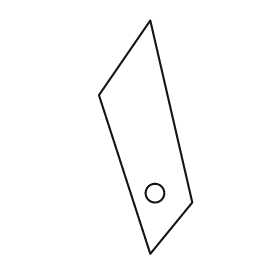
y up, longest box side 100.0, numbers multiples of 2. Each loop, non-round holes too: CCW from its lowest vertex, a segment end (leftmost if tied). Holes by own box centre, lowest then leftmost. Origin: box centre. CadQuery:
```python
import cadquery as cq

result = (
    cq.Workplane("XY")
    .moveTo(2.0, -50.0)
    .lineTo(20.0, -28.0)
    .lineTo(2.0, 50.0)
    .lineTo(-20.0, 18.0)
    .close()
    .moveTo(4.0, -24.0)
    .circle(4.0)
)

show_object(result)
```